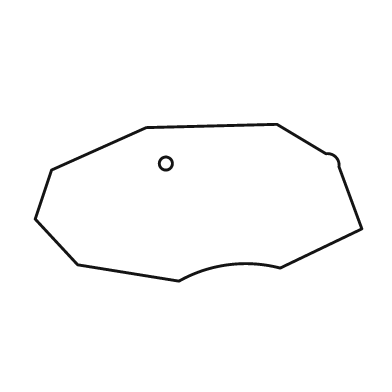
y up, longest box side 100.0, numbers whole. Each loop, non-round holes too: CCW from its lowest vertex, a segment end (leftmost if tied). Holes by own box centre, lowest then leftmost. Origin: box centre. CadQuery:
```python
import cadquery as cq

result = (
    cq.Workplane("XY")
    .moveTo(-6.0, -24.0)
    .threePointArc((9.0, -19.0), (25.0, -20.0))
    .lineTo(50.0, -8.0)
    .lineTo(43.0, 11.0)
    .threePointArc((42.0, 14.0), (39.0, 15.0))
    .lineTo(24.0, 24.0)
    .lineTo(-16.0, 23.0)
    .lineTo(-45.0, 10.0)
    .lineTo(-50.0, -5.0)
    .lineTo(-37.0, -19.0)
    .close()
    .moveTo(-10.0, 12.0)
    .circle(2.0)
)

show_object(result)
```